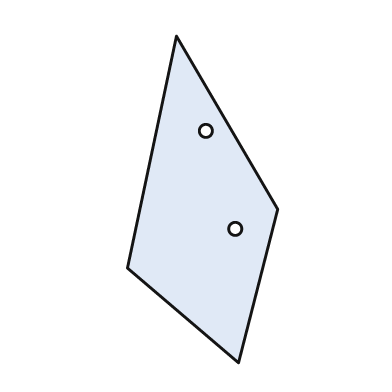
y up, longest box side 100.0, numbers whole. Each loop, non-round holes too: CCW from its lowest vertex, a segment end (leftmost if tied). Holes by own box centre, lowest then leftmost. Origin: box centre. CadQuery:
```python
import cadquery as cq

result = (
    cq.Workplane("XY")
    .moveTo(11.0, -50.0)
    .lineTo(23.0, -3.0)
    .lineTo(-8.0, 50.0)
    .lineTo(-23.0, -21.0)
    .close()
    .moveTo(10.0, -9.0)
    .circle(2.0)
    .moveTo(1.0, 21.0)
    .circle(2.0)
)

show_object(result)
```